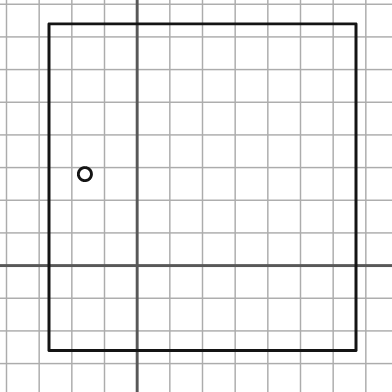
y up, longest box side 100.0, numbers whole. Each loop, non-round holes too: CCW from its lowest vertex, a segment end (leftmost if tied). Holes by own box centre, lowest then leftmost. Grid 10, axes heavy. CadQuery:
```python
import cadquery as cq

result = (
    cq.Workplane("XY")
    .moveTo(-27.0, -26.0)
    .lineTo(67.0, -26.0)
    .lineTo(67.0, 74.0)
    .lineTo(-27.0, 74.0)
    .close()
    .moveTo(-16.0, 28.0)
    .circle(2.0)
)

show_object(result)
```